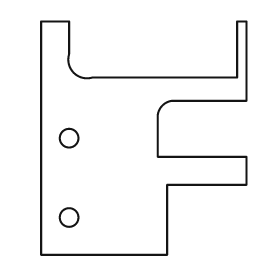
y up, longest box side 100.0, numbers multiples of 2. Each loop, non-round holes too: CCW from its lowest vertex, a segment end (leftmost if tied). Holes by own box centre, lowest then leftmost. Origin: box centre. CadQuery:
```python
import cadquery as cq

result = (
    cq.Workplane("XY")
    .moveTo(-44.0, -50.0)
    .lineTo(10.0, -50.0)
    .lineTo(10.0, -20.0)
    .lineTo(44.0, -20.0)
    .lineTo(44.0, -8.0)
    .lineTo(6.0, -8.0)
    .lineTo(6.0, 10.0)
    .threePointArc((8.0, 14.0), (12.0, 16.0))
    .lineTo(44.0, 16.0)
    .lineTo(44.0, 50.0)
    .lineTo(40.0, 50.0)
    .lineTo(40.0, 26.0)
    .lineTo(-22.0, 26.0)
    .threePointArc((-30.0, 28.0), (-32.0, 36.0))
    .lineTo(-32.0, 50.0)
    .lineTo(-44.0, 50.0)
    .close()
    .moveTo(-32.0, -34.0)
    .circle(4.0)
    .moveTo(-32.0, 0.0)
    .circle(4.0)
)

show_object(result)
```